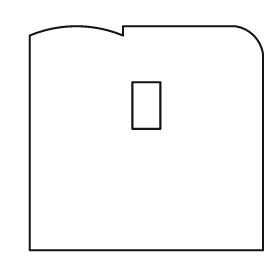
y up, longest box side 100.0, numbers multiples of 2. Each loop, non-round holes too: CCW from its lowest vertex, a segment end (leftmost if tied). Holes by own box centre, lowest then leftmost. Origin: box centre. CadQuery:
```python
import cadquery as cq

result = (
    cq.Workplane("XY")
    .moveTo(-50.0, -48.0)
    .lineTo(50.0, -48.0)
    .lineTo(50.0, 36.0)
    .threePointArc((46.0, 44.0), (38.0, 48.0))
    .lineTo(-10.0, 48.0)
    .lineTo(-10.0, 44.0)
    .threePointArc((-30.0, 48.0), (-50.0, 44.0))
    .close()
    .moveTo(-6.0, 4.0)
    .lineTo(6.0, 4.0)
    .lineTo(6.0, 24.0)
    .lineTo(-6.0, 24.0)
    .close()
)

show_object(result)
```